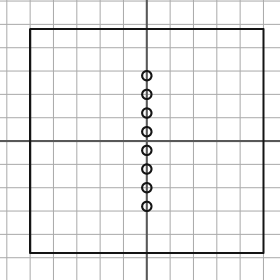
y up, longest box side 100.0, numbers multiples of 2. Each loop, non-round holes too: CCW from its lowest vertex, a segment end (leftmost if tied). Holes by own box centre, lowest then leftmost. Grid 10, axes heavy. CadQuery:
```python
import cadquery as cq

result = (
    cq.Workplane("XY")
    .moveTo(-50.0, -48.0)
    .lineTo(50.0, -48.0)
    .lineTo(50.0, 48.0)
    .lineTo(-50.0, 48.0)
    .close()
    .moveTo(0.0, -28.0)
    .circle(2.0)
    .moveTo(0.0, -20.0)
    .circle(2.0)
    .moveTo(0.0, -12.0)
    .circle(2.0)
    .moveTo(0.0, -4.0)
    .circle(2.0)
    .moveTo(0.0, 4.0)
    .circle(2.0)
    .moveTo(0.0, 12.0)
    .circle(2.0)
    .moveTo(0.0, 20.0)
    .circle(2.0)
    .moveTo(0.0, 28.0)
    .circle(2.0)
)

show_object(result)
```